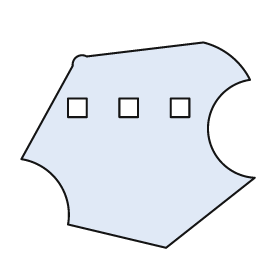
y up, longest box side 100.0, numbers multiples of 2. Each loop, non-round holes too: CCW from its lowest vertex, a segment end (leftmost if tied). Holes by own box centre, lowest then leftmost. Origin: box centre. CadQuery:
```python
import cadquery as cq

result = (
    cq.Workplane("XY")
    .moveTo(12.0, -44.0)
    .lineTo(50.0, -14.0)
    .threePointArc((30.0, 6.0), (48.0, 28.0))
    .threePointArc((40.0, 38.0), (28.0, 44.0))
    .lineTo(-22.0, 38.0)
    .threePointArc((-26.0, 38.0), (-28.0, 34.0))
    .lineTo(-50.0, -6.0)
    .threePointArc((-34.0, -16.0), (-30.0, -34.0))
    .close()
    .moveTo(-30.0, 12.0)
    .lineTo(-22.0, 12.0)
    .lineTo(-22.0, 20.0)
    .lineTo(-30.0, 20.0)
    .close()
    .moveTo(-8.0, 12.0)
    .lineTo(0.0, 12.0)
    .lineTo(0.0, 20.0)
    .lineTo(-8.0, 20.0)
    .close()
    .moveTo(14.0, 12.0)
    .lineTo(22.0, 12.0)
    .lineTo(22.0, 20.0)
    .lineTo(14.0, 20.0)
    .close()
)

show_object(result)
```